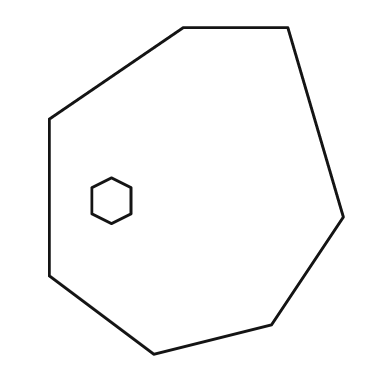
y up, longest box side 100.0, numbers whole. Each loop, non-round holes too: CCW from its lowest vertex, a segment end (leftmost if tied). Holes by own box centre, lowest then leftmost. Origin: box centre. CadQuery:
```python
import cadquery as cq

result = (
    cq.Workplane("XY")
    .moveTo(-13.0, -50.0)
    .lineTo(23.0, -41.0)
    .lineTo(45.0, -8.0)
    .lineTo(28.0, 50.0)
    .lineTo(-4.0, 50.0)
    .lineTo(-45.0, 22.0)
    .lineTo(-45.0, -26.0)
    .close()
    .moveTo(-26.0, -10.0)
    .lineTo(-20.0, -7.0)
    .lineTo(-20.0, 1.0)
    .lineTo(-26.0, 4.0)
    .lineTo(-32.0, 1.0)
    .lineTo(-32.0, -7.0)
    .close()
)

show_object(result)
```